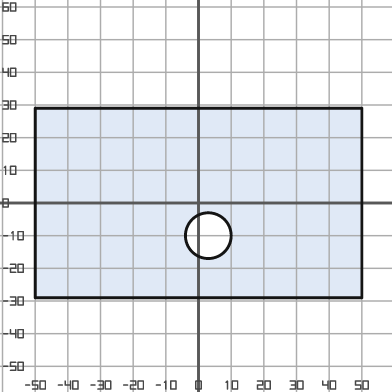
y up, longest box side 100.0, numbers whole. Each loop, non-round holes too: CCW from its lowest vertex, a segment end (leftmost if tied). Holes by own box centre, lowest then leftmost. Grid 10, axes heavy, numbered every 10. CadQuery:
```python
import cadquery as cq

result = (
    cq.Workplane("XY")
    .moveTo(-50.0, -29.0)
    .lineTo(50.0, -29.0)
    .lineTo(50.0, 29.0)
    .lineTo(-50.0, 29.0)
    .close()
    .moveTo(3.0, -10.0)
    .circle(7.0)
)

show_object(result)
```